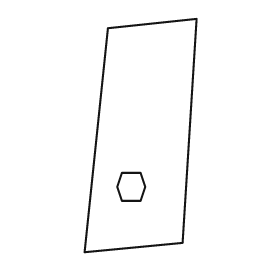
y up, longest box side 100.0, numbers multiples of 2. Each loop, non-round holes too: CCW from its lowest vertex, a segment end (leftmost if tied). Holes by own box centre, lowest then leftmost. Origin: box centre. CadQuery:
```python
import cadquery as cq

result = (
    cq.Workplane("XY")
    .moveTo(-24.0, -50.0)
    .lineTo(18.0, -46.0)
    .lineTo(24.0, 50.0)
    .lineTo(-14.0, 46.0)
    .close()
    .moveTo(-8.0, -28.0)
    .lineTo(0.0, -28.0)
    .lineTo(2.0, -22.0)
    .lineTo(0.0, -16.0)
    .lineTo(-8.0, -16.0)
    .lineTo(-10.0, -22.0)
    .close()
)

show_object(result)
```